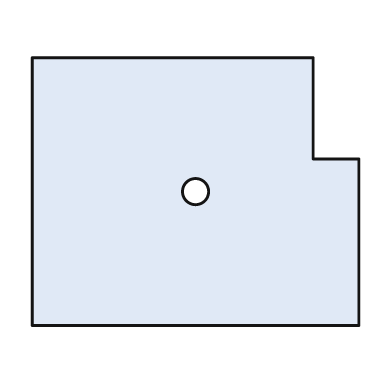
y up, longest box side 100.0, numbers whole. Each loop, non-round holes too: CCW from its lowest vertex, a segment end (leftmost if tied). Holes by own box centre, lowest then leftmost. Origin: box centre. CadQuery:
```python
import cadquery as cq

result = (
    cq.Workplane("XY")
    .moveTo(-50.0, -41.0)
    .lineTo(50.0, -41.0)
    .lineTo(50.0, 10.0)
    .lineTo(36.0, 10.0)
    .lineTo(36.0, 41.0)
    .lineTo(-50.0, 41.0)
    .close()
    .moveTo(0.0, 0.0)
    .circle(4.0)
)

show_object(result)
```